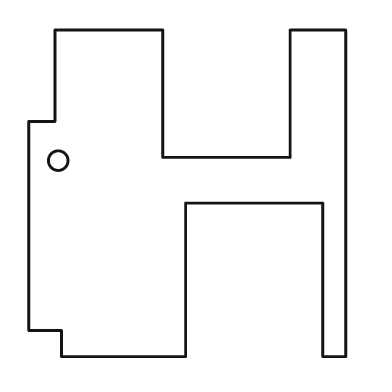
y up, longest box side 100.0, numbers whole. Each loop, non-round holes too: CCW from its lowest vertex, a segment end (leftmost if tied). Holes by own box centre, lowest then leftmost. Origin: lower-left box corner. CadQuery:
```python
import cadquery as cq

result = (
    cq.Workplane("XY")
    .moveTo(10.0, 0.0)
    .lineTo(48.0, 0.0)
    .lineTo(48.0, 47.0)
    .lineTo(90.0, 47.0)
    .lineTo(90.0, 0.0)
    .lineTo(97.0, 0.0)
    .lineTo(97.0, 100.0)
    .lineTo(80.0, 100.0)
    .lineTo(80.0, 61.0)
    .lineTo(41.0, 61.0)
    .lineTo(41.0, 100.0)
    .lineTo(8.0, 100.0)
    .lineTo(8.0, 72.0)
    .lineTo(0.0, 72.0)
    .lineTo(0.0, 8.0)
    .lineTo(10.0, 8.0)
    .close()
    .moveTo(9.0, 60.0)
    .circle(3.0)
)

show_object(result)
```